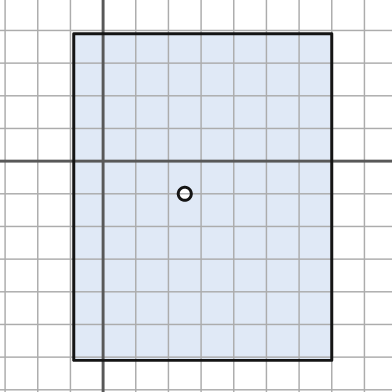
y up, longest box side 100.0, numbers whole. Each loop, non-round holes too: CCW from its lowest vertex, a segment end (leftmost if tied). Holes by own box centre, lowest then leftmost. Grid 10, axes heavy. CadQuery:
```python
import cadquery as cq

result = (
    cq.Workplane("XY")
    .moveTo(-9.0, -61.0)
    .lineTo(70.0, -61.0)
    .lineTo(70.0, 39.0)
    .lineTo(-9.0, 39.0)
    .close()
    .moveTo(25.0, -10.0)
    .circle(2.0)
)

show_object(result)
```